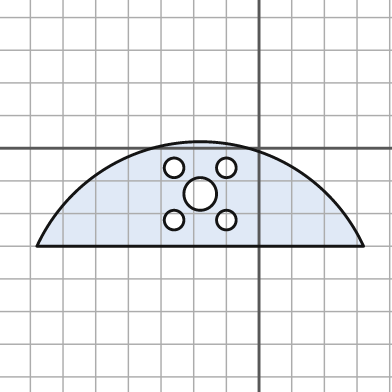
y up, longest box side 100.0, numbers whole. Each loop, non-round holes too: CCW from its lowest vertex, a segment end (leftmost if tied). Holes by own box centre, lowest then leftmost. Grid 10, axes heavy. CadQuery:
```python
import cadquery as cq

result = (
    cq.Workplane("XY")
    .moveTo(-68.0, -30.0)
    .lineTo(32.0, -30.0)
    .threePointArc((-18.0, 2.0), (-68.0, -30.0))
    .close()
    .moveTo(-26.0, -22.0)
    .circle(3.0)
    .moveTo(-10.0, -22.0)
    .circle(3.0)
    .moveTo(-18.0, -14.0)
    .circle(5.0)
    .moveTo(-26.0, -6.0)
    .circle(3.0)
    .moveTo(-10.0, -6.0)
    .circle(3.0)
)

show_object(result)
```